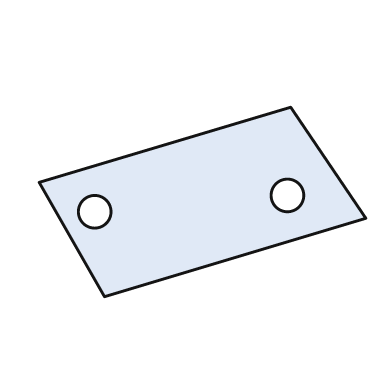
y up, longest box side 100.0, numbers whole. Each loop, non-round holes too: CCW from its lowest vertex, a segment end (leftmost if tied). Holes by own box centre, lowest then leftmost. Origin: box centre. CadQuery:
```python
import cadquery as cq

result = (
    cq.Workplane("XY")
    .moveTo(-30.0, -29.0)
    .lineTo(50.0, -5.0)
    .lineTo(27.0, 29.0)
    .lineTo(-50.0, 6.0)
    .close()
    .moveTo(-33.0, -3.0)
    .circle(5.0)
    .moveTo(26.0, 2.0)
    .circle(5.0)
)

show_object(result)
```